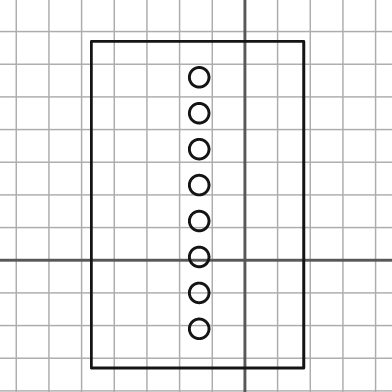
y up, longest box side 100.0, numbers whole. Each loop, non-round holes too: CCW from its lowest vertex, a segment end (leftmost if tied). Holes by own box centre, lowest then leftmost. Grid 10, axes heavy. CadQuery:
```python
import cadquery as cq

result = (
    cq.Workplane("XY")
    .moveTo(-47.0, -33.0)
    .lineTo(18.0, -33.0)
    .lineTo(18.0, 67.0)
    .lineTo(-47.0, 67.0)
    .close()
    .moveTo(-14.0, -21.0)
    .circle(3.0)
    .moveTo(-14.0, -10.0)
    .circle(3.0)
    .moveTo(-14.0, 1.0)
    .circle(3.0)
    .moveTo(-14.0, 12.0)
    .circle(3.0)
    .moveTo(-14.0, 23.0)
    .circle(3.0)
    .moveTo(-14.0, 34.0)
    .circle(3.0)
    .moveTo(-14.0, 45.0)
    .circle(3.0)
    .moveTo(-14.0, 56.0)
    .circle(3.0)
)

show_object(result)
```